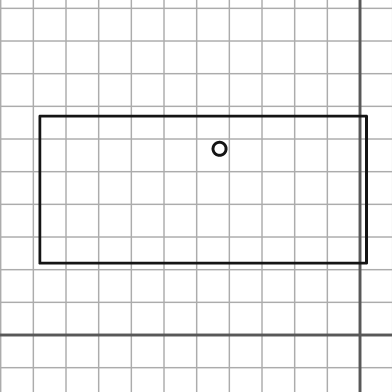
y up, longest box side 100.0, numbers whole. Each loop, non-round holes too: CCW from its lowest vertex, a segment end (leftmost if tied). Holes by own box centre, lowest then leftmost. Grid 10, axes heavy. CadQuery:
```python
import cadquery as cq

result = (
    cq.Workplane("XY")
    .moveTo(-98.0, 22.0)
    .lineTo(2.0, 22.0)
    .lineTo(2.0, 67.0)
    .lineTo(-98.0, 67.0)
    .close()
    .moveTo(-43.0, 57.0)
    .circle(2.0)
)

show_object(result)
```